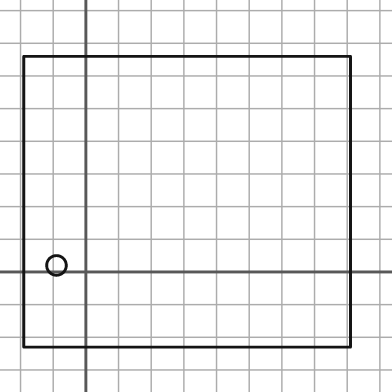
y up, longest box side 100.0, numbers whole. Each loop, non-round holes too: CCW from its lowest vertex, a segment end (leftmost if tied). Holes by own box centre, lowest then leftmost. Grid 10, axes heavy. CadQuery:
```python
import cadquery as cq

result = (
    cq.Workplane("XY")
    .moveTo(-19.0, -23.0)
    .lineTo(81.0, -23.0)
    .lineTo(81.0, 66.0)
    .lineTo(-19.0, 66.0)
    .close()
    .moveTo(-9.0, 2.0)
    .circle(3.0)
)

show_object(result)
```